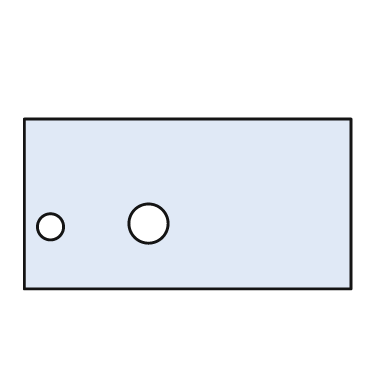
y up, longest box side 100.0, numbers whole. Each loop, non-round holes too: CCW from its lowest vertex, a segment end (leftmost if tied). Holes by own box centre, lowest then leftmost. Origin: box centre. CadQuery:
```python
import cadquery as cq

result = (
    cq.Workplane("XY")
    .moveTo(-50.0, -26.0)
    .lineTo(50.0, -26.0)
    .lineTo(50.0, 26.0)
    .lineTo(-50.0, 26.0)
    .close()
    .moveTo(-42.0, -7.0)
    .circle(4.0)
    .moveTo(-12.0, -6.0)
    .circle(6.0)
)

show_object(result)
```